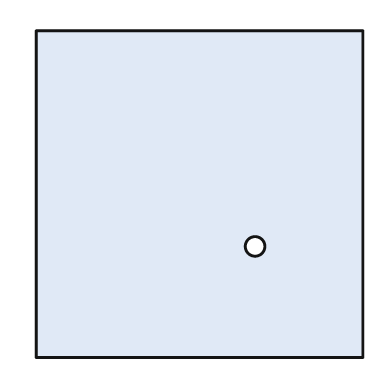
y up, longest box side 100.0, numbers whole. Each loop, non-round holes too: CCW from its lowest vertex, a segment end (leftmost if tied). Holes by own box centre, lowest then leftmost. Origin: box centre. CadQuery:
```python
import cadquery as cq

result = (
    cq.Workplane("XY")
    .moveTo(-50.0, -50.0)
    .lineTo(50.0, -50.0)
    .lineTo(50.0, 50.0)
    .lineTo(-50.0, 50.0)
    .close()
    .moveTo(17.0, -16.0)
    .circle(3.0)
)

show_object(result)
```